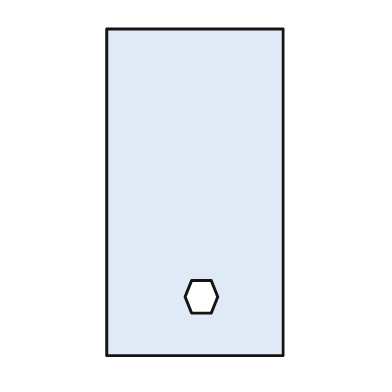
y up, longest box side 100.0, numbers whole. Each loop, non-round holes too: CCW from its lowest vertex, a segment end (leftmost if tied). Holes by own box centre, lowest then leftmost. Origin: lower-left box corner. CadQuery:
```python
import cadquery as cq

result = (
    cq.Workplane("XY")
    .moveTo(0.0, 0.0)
    .lineTo(54.0, 0.0)
    .lineTo(54.0, 100.0)
    .lineTo(0.0, 100.0)
    .close()
    .moveTo(26.0, 13.0)
    .lineTo(32.0, 13.0)
    .lineTo(34.0, 18.0)
    .lineTo(32.0, 23.0)
    .lineTo(26.0, 23.0)
    .lineTo(24.0, 18.0)
    .close()
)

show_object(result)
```